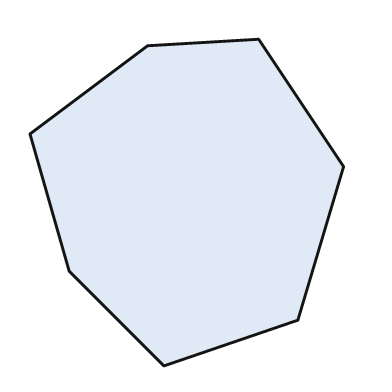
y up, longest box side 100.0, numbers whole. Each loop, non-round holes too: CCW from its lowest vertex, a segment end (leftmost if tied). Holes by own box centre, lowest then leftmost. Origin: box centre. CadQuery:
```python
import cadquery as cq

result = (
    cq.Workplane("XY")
    .moveTo(-7.0, -50.0)
    .lineTo(34.0, -36.0)
    .lineTo(48.0, 11.0)
    .lineTo(22.0, 50.0)
    .lineTo(-12.0, 48.0)
    .lineTo(-48.0, 21.0)
    .lineTo(-36.0, -21.0)
    .close()
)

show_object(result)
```